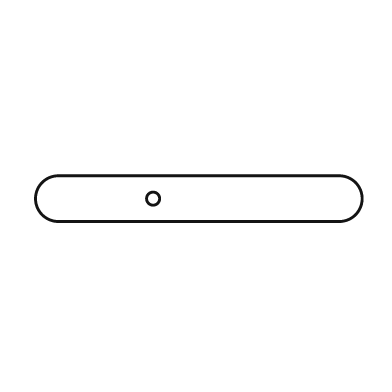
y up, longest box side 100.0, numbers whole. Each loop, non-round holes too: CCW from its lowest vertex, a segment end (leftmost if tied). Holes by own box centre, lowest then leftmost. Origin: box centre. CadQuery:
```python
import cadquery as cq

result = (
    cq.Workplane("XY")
    .moveTo(-43.0, -7.0)
    .lineTo(43.0, -7.0)
    .threePointArc((50.0, 0.0), (43.0, 7.0))
    .lineTo(-43.0, 7.0)
    .threePointArc((-50.0, 0.0), (-43.0, -7.0))
    .close()
    .moveTo(-14.0, 0.0)
    .circle(2.0)
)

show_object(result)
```